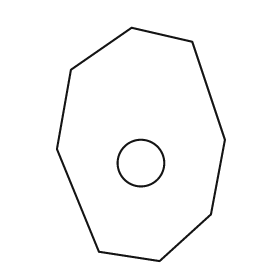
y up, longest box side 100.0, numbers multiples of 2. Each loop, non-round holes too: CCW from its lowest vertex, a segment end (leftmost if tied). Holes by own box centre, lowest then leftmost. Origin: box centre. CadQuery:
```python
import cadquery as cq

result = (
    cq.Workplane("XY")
    .moveTo(8.0, -50.0)
    .lineTo(30.0, -30.0)
    .lineTo(36.0, 2.0)
    .lineTo(22.0, 44.0)
    .lineTo(-4.0, 50.0)
    .lineTo(-30.0, 32.0)
    .lineTo(-36.0, -2.0)
    .lineTo(-18.0, -46.0)
    .close()
    .moveTo(0.0, -8.0)
    .circle(10.0)
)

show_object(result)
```